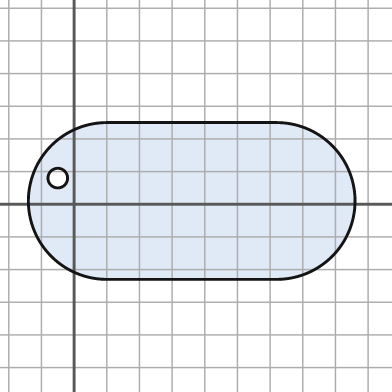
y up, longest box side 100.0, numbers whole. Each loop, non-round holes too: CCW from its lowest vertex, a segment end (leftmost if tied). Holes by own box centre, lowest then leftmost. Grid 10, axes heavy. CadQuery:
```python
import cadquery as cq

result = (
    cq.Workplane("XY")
    .moveTo(10.0, -23.0)
    .lineTo(62.0, -23.0)
    .threePointArc((86.0, 1.0), (62.0, 25.0))
    .lineTo(10.0, 25.0)
    .threePointArc((-14.0, 1.0), (10.0, -23.0))
    .close()
    .moveTo(-5.0, 8.0)
    .circle(3.0)
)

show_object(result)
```